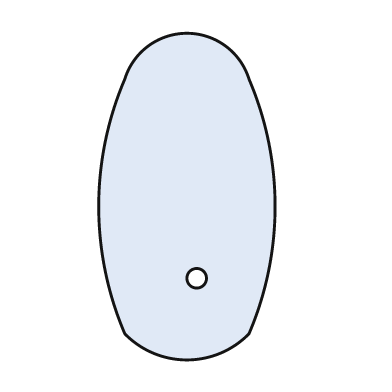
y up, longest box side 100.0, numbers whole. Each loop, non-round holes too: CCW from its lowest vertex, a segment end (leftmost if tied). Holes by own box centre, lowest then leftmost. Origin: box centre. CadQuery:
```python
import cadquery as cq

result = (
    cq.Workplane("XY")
    .moveTo(-19.0, -42.0)
    .threePointArc((0.0, -50.0), (19.0, -42.0))
    .threePointArc((27.0, -3.0), (19.0, 36.0))
    .threePointArc((0.0, 50.0), (-19.0, 36.0))
    .threePointArc((-27.0, -3.0), (-19.0, -42.0))
    .close()
    .moveTo(3.0, -25.0)
    .circle(3.0)
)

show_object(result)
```